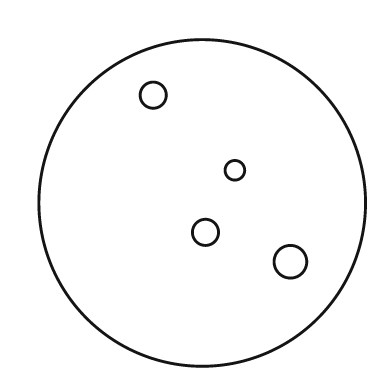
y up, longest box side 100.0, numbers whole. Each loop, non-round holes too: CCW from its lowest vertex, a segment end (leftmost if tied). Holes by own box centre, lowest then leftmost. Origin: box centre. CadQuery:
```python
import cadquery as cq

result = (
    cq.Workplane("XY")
    .moveTo(0.0, 0.0)
    .circle(50.0)
    .moveTo(27.0, -18.0)
    .circle(5.0)
    .moveTo(1.0, -9.0)
    .circle(4.0)
    .moveTo(10.0, 10.0)
    .circle(3.0)
    .moveTo(-15.0, 33.0)
    .circle(4.0)
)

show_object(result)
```